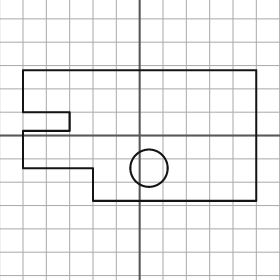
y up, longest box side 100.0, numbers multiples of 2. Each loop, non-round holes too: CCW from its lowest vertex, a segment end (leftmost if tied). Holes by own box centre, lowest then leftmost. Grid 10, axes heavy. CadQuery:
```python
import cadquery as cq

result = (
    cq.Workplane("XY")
    .moveTo(-20.0, -28.0)
    .lineTo(50.0, -28.0)
    .lineTo(50.0, 28.0)
    .lineTo(-50.0, 28.0)
    .lineTo(-50.0, 10.0)
    .lineTo(-30.0, 10.0)
    .lineTo(-30.0, 2.0)
    .lineTo(-50.0, 2.0)
    .lineTo(-50.0, -14.0)
    .lineTo(-20.0, -14.0)
    .close()
    .moveTo(4.0, -14.0)
    .circle(8.0)
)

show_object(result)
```